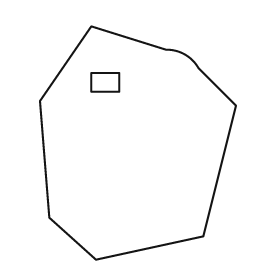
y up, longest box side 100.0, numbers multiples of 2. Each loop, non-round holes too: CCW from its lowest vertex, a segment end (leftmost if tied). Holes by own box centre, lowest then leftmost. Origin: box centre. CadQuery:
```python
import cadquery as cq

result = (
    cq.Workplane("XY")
    .moveTo(-18.0, -50.0)
    .lineTo(28.0, -40.0)
    .lineTo(42.0, 16.0)
    .lineTo(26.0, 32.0)
    .threePointArc((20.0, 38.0), (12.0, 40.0))
    .lineTo(-20.0, 50.0)
    .lineTo(-42.0, 18.0)
    .lineTo(-38.0, -32.0)
    .close()
    .moveTo(-20.0, 22.0)
    .lineTo(-8.0, 22.0)
    .lineTo(-8.0, 30.0)
    .lineTo(-20.0, 30.0)
    .close()
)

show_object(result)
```